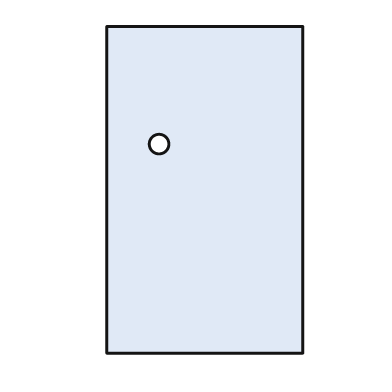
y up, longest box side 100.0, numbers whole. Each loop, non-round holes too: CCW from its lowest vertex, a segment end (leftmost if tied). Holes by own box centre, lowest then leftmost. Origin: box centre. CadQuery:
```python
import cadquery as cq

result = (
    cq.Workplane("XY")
    .moveTo(-30.0, -50.0)
    .lineTo(30.0, -50.0)
    .lineTo(30.0, 50.0)
    .lineTo(-30.0, 50.0)
    .close()
    .moveTo(-14.0, 14.0)
    .circle(3.0)
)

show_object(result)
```